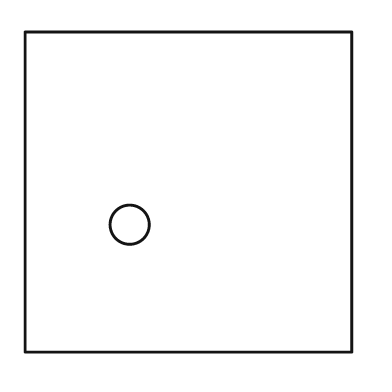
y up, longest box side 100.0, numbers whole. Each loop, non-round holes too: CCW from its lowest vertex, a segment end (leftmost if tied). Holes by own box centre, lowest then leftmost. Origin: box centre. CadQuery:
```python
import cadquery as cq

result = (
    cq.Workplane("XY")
    .moveTo(-50.0, -49.0)
    .lineTo(50.0, -49.0)
    .lineTo(50.0, 49.0)
    .lineTo(-50.0, 49.0)
    .close()
    .moveTo(-18.0, -10.0)
    .circle(6.0)
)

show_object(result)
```